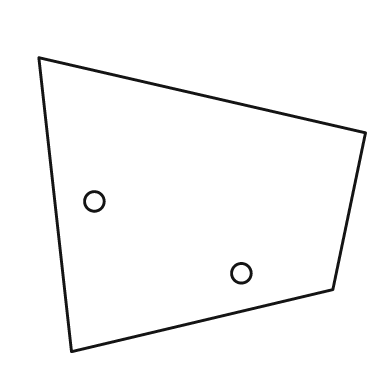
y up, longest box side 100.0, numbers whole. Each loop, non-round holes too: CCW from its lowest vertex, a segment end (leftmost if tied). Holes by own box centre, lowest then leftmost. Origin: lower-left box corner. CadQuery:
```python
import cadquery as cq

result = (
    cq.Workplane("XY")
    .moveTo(10.0, 0.0)
    .lineTo(90.0, 19.0)
    .lineTo(100.0, 67.0)
    .lineTo(0.0, 90.0)
    .close()
    .moveTo(62.0, 24.0)
    .circle(3.0)
    .moveTo(17.0, 46.0)
    .circle(3.0)
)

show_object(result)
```